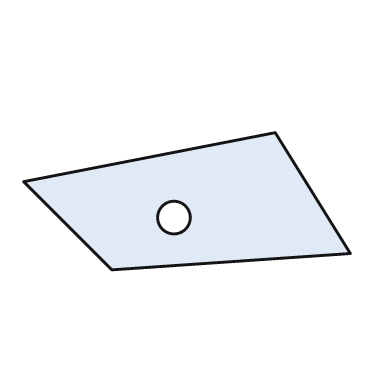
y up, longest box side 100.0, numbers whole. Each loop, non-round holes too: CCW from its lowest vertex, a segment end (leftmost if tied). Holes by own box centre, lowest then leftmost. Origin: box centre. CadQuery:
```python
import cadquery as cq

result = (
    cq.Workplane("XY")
    .moveTo(-23.0, -21.0)
    .lineTo(50.0, -16.0)
    .lineTo(27.0, 21.0)
    .lineTo(-50.0, 6.0)
    .close()
    .moveTo(-4.0, -5.0)
    .circle(5.0)
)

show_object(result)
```